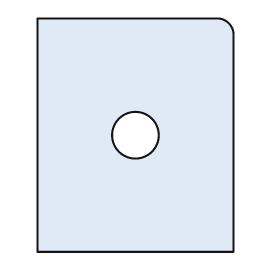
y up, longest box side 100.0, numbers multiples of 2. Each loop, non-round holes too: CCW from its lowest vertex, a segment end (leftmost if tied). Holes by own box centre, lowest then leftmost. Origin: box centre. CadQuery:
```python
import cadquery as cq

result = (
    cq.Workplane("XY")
    .moveTo(-42.0, -50.0)
    .lineTo(42.0, -50.0)
    .lineTo(42.0, 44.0)
    .threePointArc((40.0, 48.0), (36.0, 50.0))
    .lineTo(-42.0, 50.0)
    .close()
    .moveTo(0.0, 0.0)
    .circle(10.0)
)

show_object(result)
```